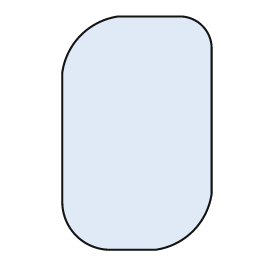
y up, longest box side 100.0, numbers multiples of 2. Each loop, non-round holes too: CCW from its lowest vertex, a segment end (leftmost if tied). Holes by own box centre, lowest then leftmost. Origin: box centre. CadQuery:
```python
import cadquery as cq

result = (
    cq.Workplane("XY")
    .moveTo(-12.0, -50.0)
    .lineTo(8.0, -50.0)
    .threePointArc((24.0, -42.0), (32.0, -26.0))
    .lineTo(32.0, 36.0)
    .threePointArc((28.0, 46.0), (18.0, 50.0))
    .lineTo(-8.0, 50.0)
    .threePointArc((-24.0, 42.0), (-32.0, 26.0))
    .lineTo(-32.0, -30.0)
    .threePointArc((-26.0, -44.0), (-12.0, -50.0))
    .close()
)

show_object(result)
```